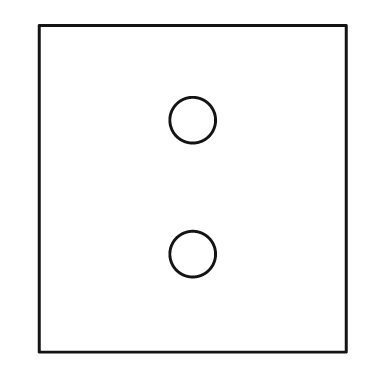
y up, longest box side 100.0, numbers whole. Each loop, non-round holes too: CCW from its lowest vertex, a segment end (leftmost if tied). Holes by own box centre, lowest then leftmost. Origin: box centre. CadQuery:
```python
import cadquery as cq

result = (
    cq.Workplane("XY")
    .moveTo(-47.0, -50.0)
    .lineTo(47.0, -50.0)
    .lineTo(47.0, 50.0)
    .lineTo(-47.0, 50.0)
    .close()
    .moveTo(0.0, -20.0)
    .circle(7.0)
    .moveTo(0.0, 21.0)
    .circle(7.0)
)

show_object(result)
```